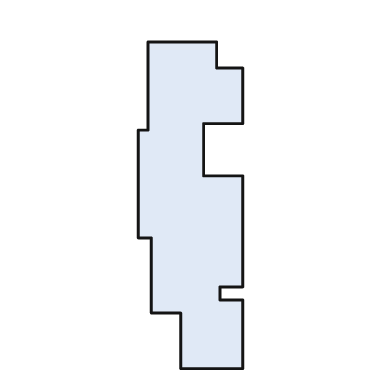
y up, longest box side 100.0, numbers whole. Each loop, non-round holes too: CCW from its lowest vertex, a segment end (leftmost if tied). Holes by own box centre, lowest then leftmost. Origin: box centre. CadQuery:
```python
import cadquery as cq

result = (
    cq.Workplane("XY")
    .moveTo(-3.0, -50.0)
    .lineTo(16.0, -50.0)
    .lineTo(16.0, -29.0)
    .lineTo(9.0, -29.0)
    .lineTo(9.0, -25.0)
    .lineTo(16.0, -25.0)
    .lineTo(16.0, 9.0)
    .lineTo(4.0, 9.0)
    .lineTo(4.0, 25.0)
    .lineTo(16.0, 25.0)
    .lineTo(16.0, 42.0)
    .lineTo(8.0, 42.0)
    .lineTo(8.0, 50.0)
    .lineTo(-13.0, 50.0)
    .lineTo(-13.0, 23.0)
    .lineTo(-16.0, 23.0)
    .lineTo(-16.0, -10.0)
    .lineTo(-12.0, -10.0)
    .lineTo(-12.0, -33.0)
    .lineTo(-3.0, -33.0)
    .close()
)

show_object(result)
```